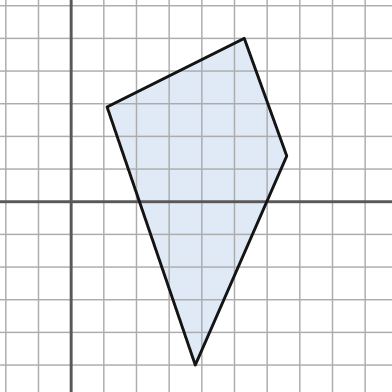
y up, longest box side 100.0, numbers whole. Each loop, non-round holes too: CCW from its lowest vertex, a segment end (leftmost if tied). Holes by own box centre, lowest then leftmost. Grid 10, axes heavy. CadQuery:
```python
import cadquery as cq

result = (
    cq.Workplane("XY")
    .moveTo(38.0, -50.0)
    .lineTo(66.0, 14.0)
    .lineTo(53.0, 50.0)
    .lineTo(11.0, 29.0)
    .close()
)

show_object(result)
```